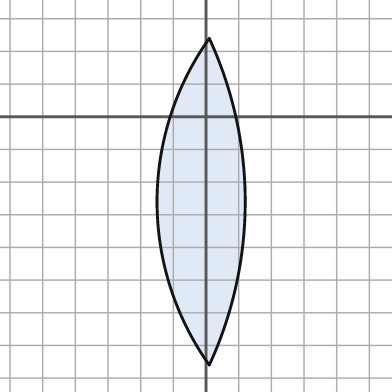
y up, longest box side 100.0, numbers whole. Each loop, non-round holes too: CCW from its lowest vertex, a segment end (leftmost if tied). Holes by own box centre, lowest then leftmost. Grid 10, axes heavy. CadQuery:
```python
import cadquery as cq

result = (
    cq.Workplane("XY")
    .moveTo(1.0, -76.0)
    .threePointArc((12.0, -26.0), (1.0, 24.0))
    .threePointArc((-15.0, -26.0), (1.0, -76.0))
    .close()
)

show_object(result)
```